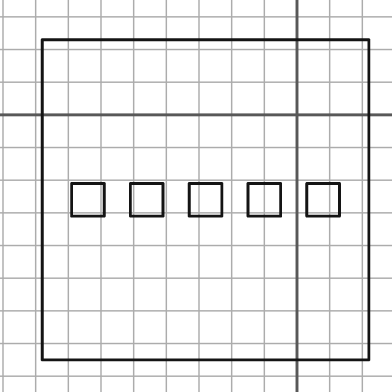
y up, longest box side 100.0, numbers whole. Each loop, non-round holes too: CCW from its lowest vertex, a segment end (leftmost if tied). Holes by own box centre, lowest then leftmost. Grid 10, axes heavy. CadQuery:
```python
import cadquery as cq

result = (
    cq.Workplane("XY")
    .moveTo(-78.0, -75.0)
    .lineTo(22.0, -75.0)
    .lineTo(22.0, 23.0)
    .lineTo(-78.0, 23.0)
    .close()
    .moveTo(-69.0, -31.0)
    .lineTo(-59.0, -31.0)
    .lineTo(-59.0, -21.0)
    .lineTo(-69.0, -21.0)
    .close()
    .moveTo(-51.0, -31.0)
    .lineTo(-41.0, -31.0)
    .lineTo(-41.0, -21.0)
    .lineTo(-51.0, -21.0)
    .close()
    .moveTo(-33.0, -31.0)
    .lineTo(-23.0, -31.0)
    .lineTo(-23.0, -21.0)
    .lineTo(-33.0, -21.0)
    .close()
    .moveTo(-15.0, -31.0)
    .lineTo(-5.0, -31.0)
    .lineTo(-5.0, -21.0)
    .lineTo(-15.0, -21.0)
    .close()
    .moveTo(3.0, -31.0)
    .lineTo(13.0, -31.0)
    .lineTo(13.0, -21.0)
    .lineTo(3.0, -21.0)
    .close()
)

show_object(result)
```